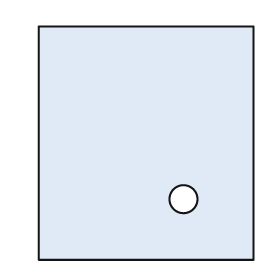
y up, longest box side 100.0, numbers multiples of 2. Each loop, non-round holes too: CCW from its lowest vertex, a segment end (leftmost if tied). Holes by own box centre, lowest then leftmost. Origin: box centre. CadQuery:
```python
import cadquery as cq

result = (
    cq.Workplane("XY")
    .moveTo(-46.0, -50.0)
    .lineTo(46.0, -50.0)
    .lineTo(46.0, 50.0)
    .lineTo(-46.0, 50.0)
    .close()
    .moveTo(16.0, -24.0)
    .circle(6.0)
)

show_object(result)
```